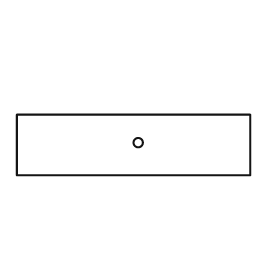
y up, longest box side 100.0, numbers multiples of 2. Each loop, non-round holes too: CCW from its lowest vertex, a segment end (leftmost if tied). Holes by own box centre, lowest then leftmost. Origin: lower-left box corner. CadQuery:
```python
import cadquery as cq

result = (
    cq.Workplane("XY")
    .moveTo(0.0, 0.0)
    .lineTo(100.0, 0.0)
    .lineTo(100.0, 26.0)
    .lineTo(0.0, 26.0)
    .close()
    .moveTo(52.0, 14.0)
    .circle(2.0)
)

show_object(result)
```